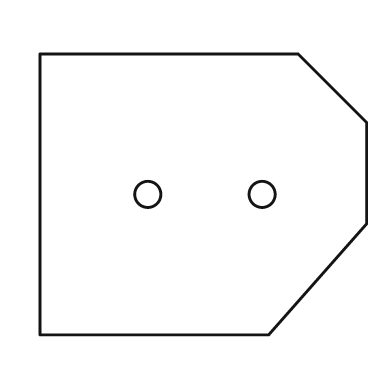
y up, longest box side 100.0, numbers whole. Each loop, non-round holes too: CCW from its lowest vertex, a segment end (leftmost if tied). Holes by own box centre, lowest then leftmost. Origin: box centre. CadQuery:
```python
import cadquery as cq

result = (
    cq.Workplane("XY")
    .moveTo(-50.0, -43.0)
    .lineTo(20.0, -43.0)
    .lineTo(50.0, -9.0)
    .lineTo(50.0, 22.0)
    .lineTo(29.0, 43.0)
    .lineTo(-50.0, 43.0)
    .close()
    .moveTo(-17.0, 0.0)
    .circle(4.0)
    .moveTo(18.0, 0.0)
    .circle(4.0)
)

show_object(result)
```